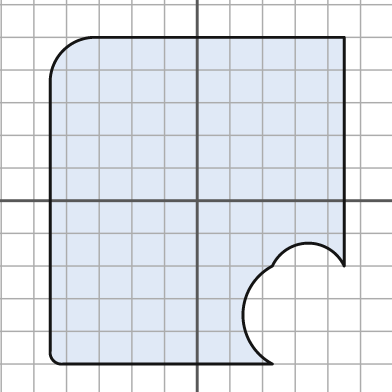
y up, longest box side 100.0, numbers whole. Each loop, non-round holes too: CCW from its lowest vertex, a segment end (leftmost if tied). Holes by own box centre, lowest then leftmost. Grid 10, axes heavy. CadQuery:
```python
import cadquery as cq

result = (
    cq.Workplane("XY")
    .moveTo(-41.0, -50.0)
    .lineTo(23.0, -50.0)
    .threePointArc((14.0, -35.0), (23.0, -20.0))
    .threePointArc((34.0, -13.0), (45.0, -20.0))
    .lineTo(45.0, 50.0)
    .lineTo(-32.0, 50.0)
    .threePointArc((-41.0, 46.0), (-45.0, 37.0))
    .lineTo(-45.0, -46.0)
    .threePointArc((-44.0, -49.0), (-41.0, -50.0))
    .close()
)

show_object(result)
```